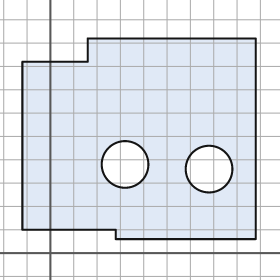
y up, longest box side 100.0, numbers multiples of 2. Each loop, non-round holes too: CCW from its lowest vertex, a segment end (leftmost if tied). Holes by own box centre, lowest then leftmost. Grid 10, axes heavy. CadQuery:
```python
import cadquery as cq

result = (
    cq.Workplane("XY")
    .moveTo(28.0, 6.0)
    .lineTo(88.0, 6.0)
    .lineTo(88.0, 92.0)
    .lineTo(16.0, 92.0)
    .lineTo(16.0, 82.0)
    .lineTo(-12.0, 82.0)
    .lineTo(-12.0, 10.0)
    .lineTo(28.0, 10.0)
    .close()
    .moveTo(68.0, 36.0)
    .circle(10.0)
    .moveTo(32.0, 38.0)
    .circle(10.0)
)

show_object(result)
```